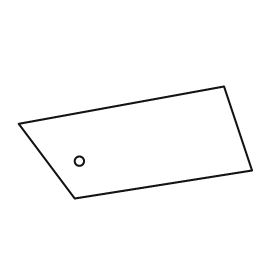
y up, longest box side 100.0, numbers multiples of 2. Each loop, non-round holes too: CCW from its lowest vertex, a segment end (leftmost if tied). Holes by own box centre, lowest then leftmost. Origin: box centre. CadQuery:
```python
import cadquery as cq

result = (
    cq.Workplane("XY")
    .moveTo(-26.0, -24.0)
    .lineTo(50.0, -12.0)
    .lineTo(38.0, 24.0)
    .lineTo(-50.0, 8.0)
    .close()
    .moveTo(-24.0, -8.0)
    .circle(2.0)
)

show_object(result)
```